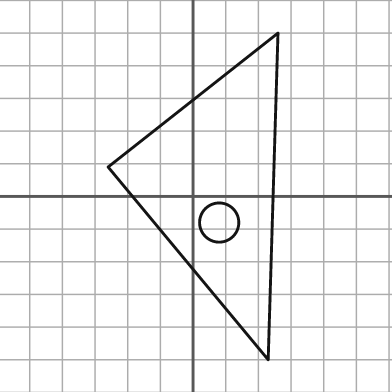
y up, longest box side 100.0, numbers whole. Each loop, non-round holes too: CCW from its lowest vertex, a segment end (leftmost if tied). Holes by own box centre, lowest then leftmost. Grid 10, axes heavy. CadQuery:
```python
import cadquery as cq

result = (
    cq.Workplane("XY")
    .moveTo(23.0, -50.0)
    .lineTo(26.0, 50.0)
    .lineTo(-26.0, 9.0)
    .close()
    .moveTo(8.0, -8.0)
    .circle(6.0)
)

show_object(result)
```